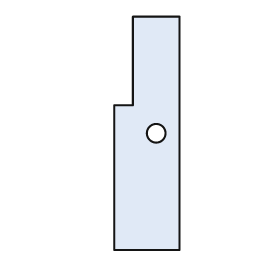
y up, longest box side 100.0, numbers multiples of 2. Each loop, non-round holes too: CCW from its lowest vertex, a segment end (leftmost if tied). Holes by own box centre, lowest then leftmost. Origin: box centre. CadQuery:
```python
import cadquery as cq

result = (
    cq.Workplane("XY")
    .moveTo(-14.0, -50.0)
    .lineTo(14.0, -50.0)
    .lineTo(14.0, 50.0)
    .lineTo(-6.0, 50.0)
    .lineTo(-6.0, 12.0)
    .lineTo(-14.0, 12.0)
    .close()
    .moveTo(4.0, 0.0)
    .circle(4.0)
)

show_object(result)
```